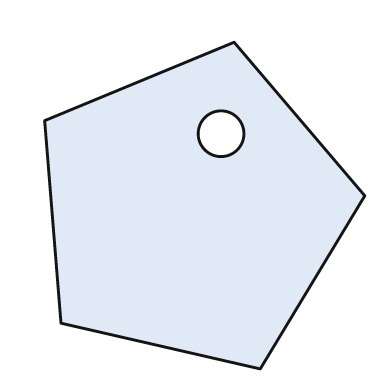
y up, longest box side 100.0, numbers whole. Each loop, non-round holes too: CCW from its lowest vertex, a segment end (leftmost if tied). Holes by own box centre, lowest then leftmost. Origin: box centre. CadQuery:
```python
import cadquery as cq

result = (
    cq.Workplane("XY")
    .moveTo(17.0, -50.0)
    .lineTo(49.0, 3.0)
    .lineTo(9.0, 50.0)
    .lineTo(-49.0, 26.0)
    .lineTo(-44.0, -36.0)
    .close()
    .moveTo(5.0, 22.0)
    .circle(7.0)
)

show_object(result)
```